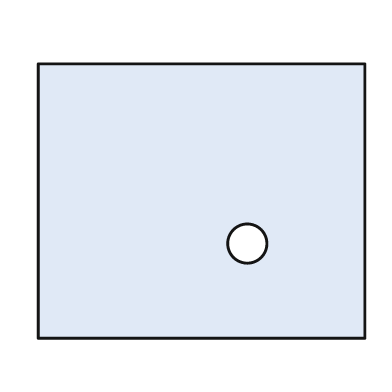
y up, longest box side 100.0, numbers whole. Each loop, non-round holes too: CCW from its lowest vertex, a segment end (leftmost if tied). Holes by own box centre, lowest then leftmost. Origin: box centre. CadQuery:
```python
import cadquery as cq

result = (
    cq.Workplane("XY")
    .moveTo(-50.0, -42.0)
    .lineTo(50.0, -42.0)
    .lineTo(50.0, 42.0)
    .lineTo(-50.0, 42.0)
    .close()
    .moveTo(14.0, -13.0)
    .circle(6.0)
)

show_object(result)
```